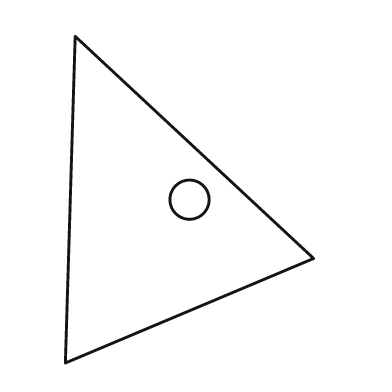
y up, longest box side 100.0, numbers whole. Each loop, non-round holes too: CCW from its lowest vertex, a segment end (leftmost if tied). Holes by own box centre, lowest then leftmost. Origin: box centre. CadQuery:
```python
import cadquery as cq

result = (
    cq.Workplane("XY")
    .moveTo(-38.0, -50.0)
    .lineTo(38.0, -18.0)
    .lineTo(-35.0, 50.0)
    .close()
    .moveTo(0.0, 0.0)
    .circle(6.0)
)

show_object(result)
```